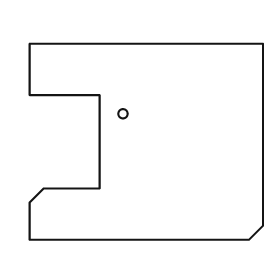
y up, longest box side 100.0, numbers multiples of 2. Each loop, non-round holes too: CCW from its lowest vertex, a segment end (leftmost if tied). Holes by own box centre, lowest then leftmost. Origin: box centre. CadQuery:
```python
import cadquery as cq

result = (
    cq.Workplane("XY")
    .moveTo(-50.0, -42.0)
    .lineTo(44.0, -42.0)
    .lineTo(50.0, -36.0)
    .lineTo(50.0, 42.0)
    .lineTo(-50.0, 42.0)
    .lineTo(-50.0, 20.0)
    .lineTo(-20.0, 20.0)
    .lineTo(-20.0, -20.0)
    .lineTo(-44.0, -20.0)
    .lineTo(-50.0, -26.0)
    .close()
    .moveTo(-10.0, 12.0)
    .circle(2.0)
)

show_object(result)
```